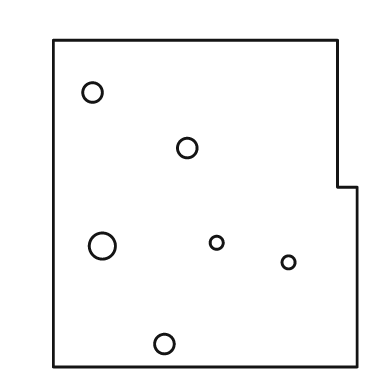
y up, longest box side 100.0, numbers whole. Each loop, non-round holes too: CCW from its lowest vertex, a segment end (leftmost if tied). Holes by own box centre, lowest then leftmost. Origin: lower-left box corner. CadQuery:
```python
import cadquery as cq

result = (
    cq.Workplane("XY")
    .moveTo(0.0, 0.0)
    .lineTo(93.0, 0.0)
    .lineTo(93.0, 55.0)
    .lineTo(87.0, 55.0)
    .lineTo(87.0, 100.0)
    .lineTo(0.0, 100.0)
    .close()
    .moveTo(34.0, 7.0)
    .circle(3.0)
    .moveTo(72.0, 32.0)
    .circle(2.0)
    .moveTo(15.0, 37.0)
    .circle(4.0)
    .moveTo(50.0, 38.0)
    .circle(2.0)
    .moveTo(41.0, 67.0)
    .circle(3.0)
    .moveTo(12.0, 84.0)
    .circle(3.0)
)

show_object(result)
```